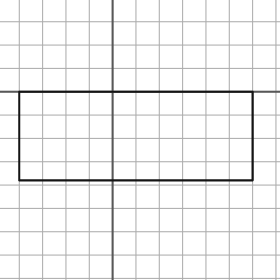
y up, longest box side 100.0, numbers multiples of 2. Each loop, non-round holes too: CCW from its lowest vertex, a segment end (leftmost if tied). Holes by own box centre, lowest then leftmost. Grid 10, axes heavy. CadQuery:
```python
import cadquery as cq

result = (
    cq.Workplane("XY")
    .moveTo(-40.0, -38.0)
    .lineTo(60.0, -38.0)
    .lineTo(60.0, 0.0)
    .lineTo(-40.0, 0.0)
    .close()
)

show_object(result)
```